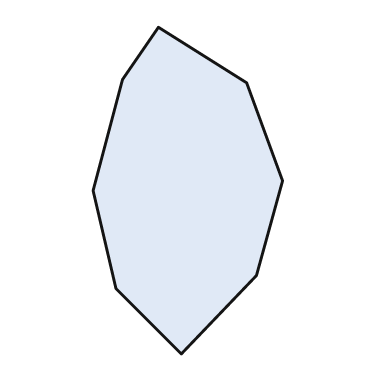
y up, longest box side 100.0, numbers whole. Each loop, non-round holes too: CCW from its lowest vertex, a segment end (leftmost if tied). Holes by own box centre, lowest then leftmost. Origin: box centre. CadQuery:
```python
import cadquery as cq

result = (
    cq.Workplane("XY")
    .moveTo(-2.0, -50.0)
    .lineTo(21.0, -26.0)
    .lineTo(29.0, 3.0)
    .lineTo(18.0, 33.0)
    .lineTo(-9.0, 50.0)
    .lineTo(-20.0, 34.0)
    .lineTo(-29.0, 0.0)
    .lineTo(-22.0, -30.0)
    .close()
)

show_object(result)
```